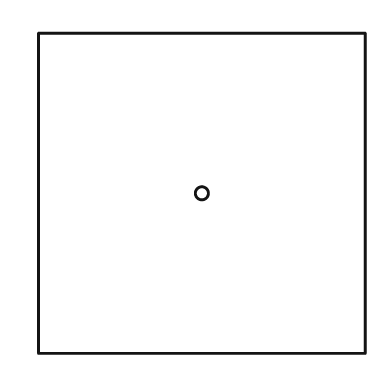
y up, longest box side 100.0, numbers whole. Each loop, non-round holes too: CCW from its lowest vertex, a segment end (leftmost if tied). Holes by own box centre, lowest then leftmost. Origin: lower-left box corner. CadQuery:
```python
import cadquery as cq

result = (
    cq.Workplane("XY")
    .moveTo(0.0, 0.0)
    .lineTo(100.0, 0.0)
    .lineTo(100.0, 98.0)
    .lineTo(0.0, 98.0)
    .close()
    .moveTo(50.0, 49.0)
    .circle(2.0)
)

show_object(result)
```